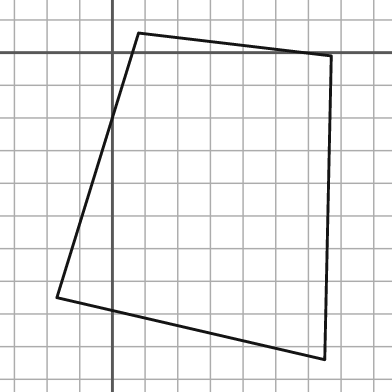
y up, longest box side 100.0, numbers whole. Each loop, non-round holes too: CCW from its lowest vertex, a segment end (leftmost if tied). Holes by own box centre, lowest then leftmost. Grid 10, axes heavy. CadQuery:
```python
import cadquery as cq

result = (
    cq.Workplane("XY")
    .moveTo(65.0, -94.0)
    .lineTo(67.0, -1.0)
    .lineTo(8.0, 6.0)
    .lineTo(-17.0, -75.0)
    .close()
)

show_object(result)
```